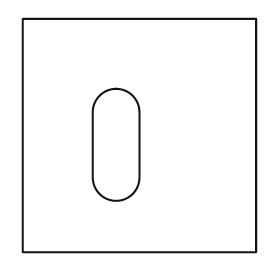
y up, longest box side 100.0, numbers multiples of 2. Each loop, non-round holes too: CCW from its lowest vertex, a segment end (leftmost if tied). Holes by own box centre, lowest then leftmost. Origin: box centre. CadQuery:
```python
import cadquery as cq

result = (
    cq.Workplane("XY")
    .moveTo(-50.0, -50.0)
    .lineTo(50.0, -50.0)
    .lineTo(50.0, 50.0)
    .lineTo(-50.0, 50.0)
    .close()
    .moveTo(-20.0, -18.0)
    .threePointArc((-10.0, -28.0), (0.0, -18.0))
    .lineTo(0.0, 10.0)
    .threePointArc((-10.0, 20.0), (-20.0, 10.0))
    .close()
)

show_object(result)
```